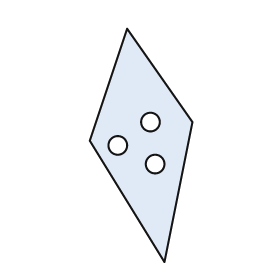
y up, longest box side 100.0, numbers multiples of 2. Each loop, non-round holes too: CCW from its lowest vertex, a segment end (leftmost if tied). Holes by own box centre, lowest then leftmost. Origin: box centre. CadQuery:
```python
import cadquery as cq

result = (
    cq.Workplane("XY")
    .moveTo(10.0, -50.0)
    .lineTo(22.0, 10.0)
    .lineTo(-6.0, 50.0)
    .lineTo(-22.0, 2.0)
    .close()
    .moveTo(6.0, -8.0)
    .circle(4.0)
    .moveTo(-10.0, 0.0)
    .circle(4.0)
    .moveTo(4.0, 10.0)
    .circle(4.0)
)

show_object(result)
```